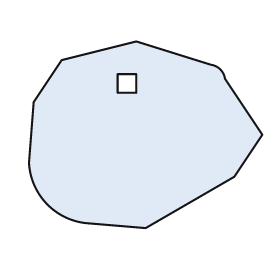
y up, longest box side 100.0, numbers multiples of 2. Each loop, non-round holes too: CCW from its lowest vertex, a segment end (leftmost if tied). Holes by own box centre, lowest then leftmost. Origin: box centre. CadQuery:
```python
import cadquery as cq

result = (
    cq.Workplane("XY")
    .moveTo(0.0, -40.0)
    .lineTo(38.0, -18.0)
    .lineTo(50.0, 0.0)
    .lineTo(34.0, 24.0)
    .threePointArc((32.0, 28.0), (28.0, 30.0))
    .lineTo(-4.0, 40.0)
    .lineTo(-36.0, 32.0)
    .lineTo(-48.0, 14.0)
    .lineTo(-50.0, -12.0)
    .threePointArc((-42.0, -30.0), (-24.0, -38.0))
    .close()
    .moveTo(-12.0, 18.0)
    .lineTo(-4.0, 18.0)
    .lineTo(-4.0, 26.0)
    .lineTo(-12.0, 26.0)
    .close()
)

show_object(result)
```